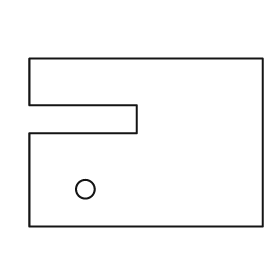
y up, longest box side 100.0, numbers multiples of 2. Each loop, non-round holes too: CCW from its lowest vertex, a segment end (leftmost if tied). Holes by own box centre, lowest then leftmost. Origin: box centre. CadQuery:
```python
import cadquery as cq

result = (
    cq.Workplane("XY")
    .moveTo(-50.0, -36.0)
    .lineTo(50.0, -36.0)
    .lineTo(50.0, 36.0)
    .lineTo(-50.0, 36.0)
    .lineTo(-50.0, 16.0)
    .lineTo(-4.0, 16.0)
    .lineTo(-4.0, 4.0)
    .lineTo(-50.0, 4.0)
    .close()
    .moveTo(-26.0, -20.0)
    .circle(4.0)
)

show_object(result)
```